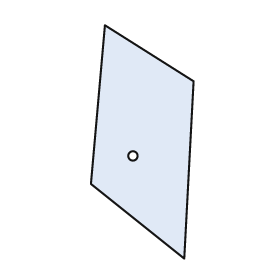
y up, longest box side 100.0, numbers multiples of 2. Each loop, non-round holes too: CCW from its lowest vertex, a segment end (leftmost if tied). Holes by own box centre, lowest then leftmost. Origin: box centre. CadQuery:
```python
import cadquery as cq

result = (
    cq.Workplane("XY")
    .moveTo(18.0, -50.0)
    .lineTo(22.0, 26.0)
    .lineTo(-16.0, 50.0)
    .lineTo(-22.0, -18.0)
    .close()
    .moveTo(-4.0, -6.0)
    .circle(2.0)
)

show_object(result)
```